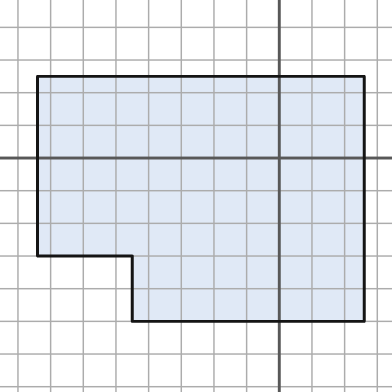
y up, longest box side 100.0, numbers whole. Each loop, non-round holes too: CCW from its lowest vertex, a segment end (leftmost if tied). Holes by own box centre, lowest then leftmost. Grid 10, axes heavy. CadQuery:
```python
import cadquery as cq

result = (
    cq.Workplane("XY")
    .moveTo(-45.0, -50.0)
    .lineTo(26.0, -50.0)
    .lineTo(26.0, 25.0)
    .lineTo(-74.0, 25.0)
    .lineTo(-74.0, -30.0)
    .lineTo(-45.0, -30.0)
    .close()
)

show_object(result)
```